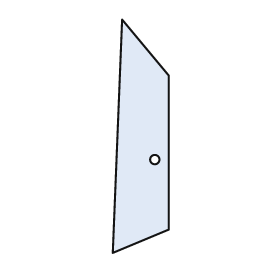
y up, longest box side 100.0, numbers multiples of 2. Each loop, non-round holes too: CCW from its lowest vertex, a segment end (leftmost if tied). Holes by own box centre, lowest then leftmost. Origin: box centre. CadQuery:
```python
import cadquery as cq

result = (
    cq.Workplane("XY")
    .moveTo(-12.0, -50.0)
    .lineTo(12.0, -40.0)
    .lineTo(12.0, 26.0)
    .lineTo(-8.0, 50.0)
    .close()
    .moveTo(6.0, -10.0)
    .circle(2.0)
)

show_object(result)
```